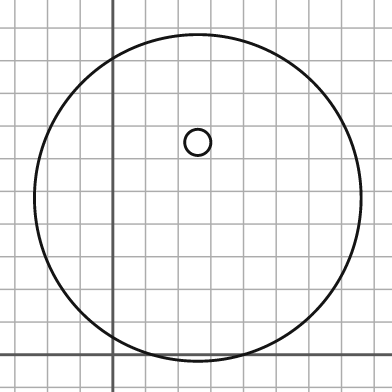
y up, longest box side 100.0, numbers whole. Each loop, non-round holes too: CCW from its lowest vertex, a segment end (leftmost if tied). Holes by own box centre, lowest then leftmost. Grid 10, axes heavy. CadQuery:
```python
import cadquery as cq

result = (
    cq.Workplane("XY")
    .moveTo(26.0, 48.0)
    .circle(50.0)
    .moveTo(26.0, 65.0)
    .circle(4.0)
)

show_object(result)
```